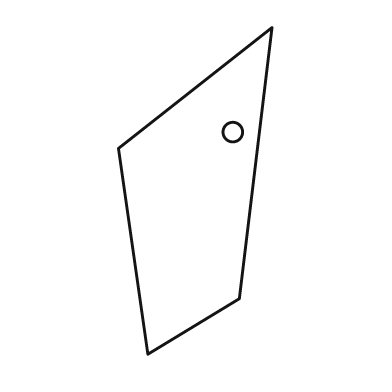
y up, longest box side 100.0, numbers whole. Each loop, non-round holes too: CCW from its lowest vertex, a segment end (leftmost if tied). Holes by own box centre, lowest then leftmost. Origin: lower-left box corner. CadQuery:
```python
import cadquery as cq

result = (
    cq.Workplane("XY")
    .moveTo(9.0, 0.0)
    .lineTo(37.0, 17.0)
    .lineTo(47.0, 100.0)
    .lineTo(0.0, 63.0)
    .close()
    .moveTo(35.0, 68.0)
    .circle(3.0)
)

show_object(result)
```